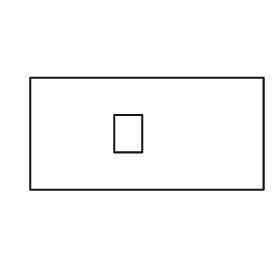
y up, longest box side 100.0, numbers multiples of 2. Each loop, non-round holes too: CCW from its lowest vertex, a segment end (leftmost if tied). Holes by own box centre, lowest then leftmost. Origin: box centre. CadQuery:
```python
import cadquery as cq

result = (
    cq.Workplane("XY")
    .moveTo(-50.0, -24.0)
    .lineTo(50.0, -24.0)
    .lineTo(50.0, 24.0)
    .lineTo(-50.0, 24.0)
    .close()
    .moveTo(-14.0, -8.0)
    .lineTo(-2.0, -8.0)
    .lineTo(-2.0, 8.0)
    .lineTo(-14.0, 8.0)
    .close()
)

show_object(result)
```